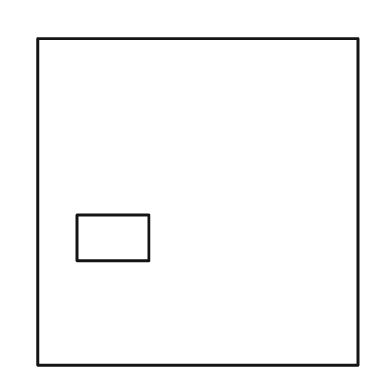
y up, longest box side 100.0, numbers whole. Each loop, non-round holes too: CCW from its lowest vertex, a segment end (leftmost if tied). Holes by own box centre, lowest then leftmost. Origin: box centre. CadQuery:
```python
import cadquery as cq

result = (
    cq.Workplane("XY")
    .moveTo(-49.0, -50.0)
    .lineTo(49.0, -50.0)
    .lineTo(49.0, 50.0)
    .lineTo(-49.0, 50.0)
    .close()
    .moveTo(-37.0, -18.0)
    .lineTo(-15.0, -18.0)
    .lineTo(-15.0, -4.0)
    .lineTo(-37.0, -4.0)
    .close()
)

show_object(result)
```